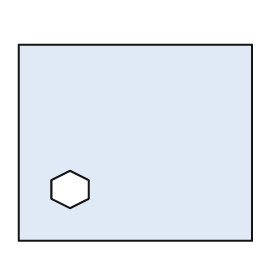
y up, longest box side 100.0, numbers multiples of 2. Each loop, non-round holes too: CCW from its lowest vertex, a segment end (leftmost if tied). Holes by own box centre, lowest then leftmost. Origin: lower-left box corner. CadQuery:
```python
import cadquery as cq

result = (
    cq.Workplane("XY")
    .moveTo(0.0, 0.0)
    .lineTo(100.0, 0.0)
    .lineTo(100.0, 84.0)
    .lineTo(0.0, 84.0)
    .close()
    .moveTo(22.0, 14.0)
    .lineTo(30.0, 18.0)
    .lineTo(30.0, 26.0)
    .lineTo(22.0, 30.0)
    .lineTo(14.0, 26.0)
    .lineTo(14.0, 18.0)
    .close()
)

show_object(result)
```